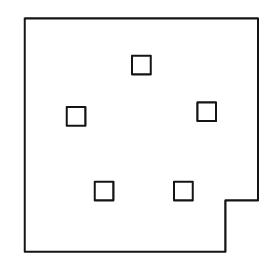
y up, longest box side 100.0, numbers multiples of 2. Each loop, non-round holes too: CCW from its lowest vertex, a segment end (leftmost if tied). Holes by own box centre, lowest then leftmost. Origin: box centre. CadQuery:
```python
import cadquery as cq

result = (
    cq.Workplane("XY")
    .moveTo(-50.0, -50.0)
    .lineTo(36.0, -50.0)
    .lineTo(36.0, -28.0)
    .lineTo(50.0, -28.0)
    .lineTo(50.0, 50.0)
    .lineTo(-50.0, 50.0)
    .close()
    .moveTo(-20.0, -28.0)
    .lineTo(-12.0, -28.0)
    .lineTo(-12.0, -20.0)
    .lineTo(-20.0, -20.0)
    .close()
    .moveTo(14.0, -28.0)
    .lineTo(22.0, -28.0)
    .lineTo(22.0, -20.0)
    .lineTo(14.0, -20.0)
    .close()
    .moveTo(-32.0, 4.0)
    .lineTo(-24.0, 4.0)
    .lineTo(-24.0, 12.0)
    .lineTo(-32.0, 12.0)
    .close()
    .moveTo(24.0, 6.0)
    .lineTo(32.0, 6.0)
    .lineTo(32.0, 14.0)
    .lineTo(24.0, 14.0)
    .close()
    .moveTo(-4.0, 26.0)
    .lineTo(4.0, 26.0)
    .lineTo(4.0, 34.0)
    .lineTo(-4.0, 34.0)
    .close()
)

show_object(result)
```